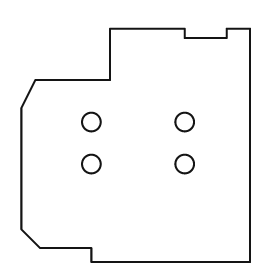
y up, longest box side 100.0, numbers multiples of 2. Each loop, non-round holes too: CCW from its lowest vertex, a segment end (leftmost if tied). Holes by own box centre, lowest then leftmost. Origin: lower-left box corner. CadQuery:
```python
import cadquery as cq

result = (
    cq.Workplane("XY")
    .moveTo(30.0, 0.0)
    .lineTo(98.0, 0.0)
    .lineTo(98.0, 100.0)
    .lineTo(88.0, 100.0)
    .lineTo(88.0, 96.0)
    .lineTo(70.0, 96.0)
    .lineTo(70.0, 100.0)
    .lineTo(38.0, 100.0)
    .lineTo(38.0, 78.0)
    .lineTo(6.0, 78.0)
    .lineTo(0.0, 66.0)
    .lineTo(0.0, 14.0)
    .lineTo(8.0, 6.0)
    .lineTo(30.0, 6.0)
    .close()
    .moveTo(30.0, 42.0)
    .circle(4.0)
    .moveTo(70.0, 42.0)
    .circle(4.0)
    .moveTo(30.0, 60.0)
    .circle(4.0)
    .moveTo(70.0, 60.0)
    .circle(4.0)
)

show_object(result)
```